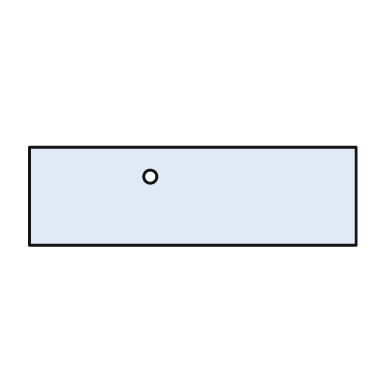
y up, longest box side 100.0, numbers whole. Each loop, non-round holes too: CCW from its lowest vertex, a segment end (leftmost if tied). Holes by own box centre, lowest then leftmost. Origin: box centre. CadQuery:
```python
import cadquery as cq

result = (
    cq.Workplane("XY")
    .moveTo(-50.0, -15.0)
    .lineTo(50.0, -15.0)
    .lineTo(50.0, 15.0)
    .lineTo(-50.0, 15.0)
    .close()
    .moveTo(-13.0, 6.0)
    .circle(2.0)
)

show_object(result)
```